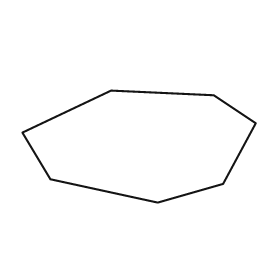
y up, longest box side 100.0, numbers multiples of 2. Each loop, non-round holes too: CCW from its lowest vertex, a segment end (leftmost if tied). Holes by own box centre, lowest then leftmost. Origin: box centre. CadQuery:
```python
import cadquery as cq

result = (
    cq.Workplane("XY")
    .moveTo(8.0, -24.0)
    .lineTo(36.0, -16.0)
    .lineTo(50.0, 10.0)
    .lineTo(32.0, 22.0)
    .lineTo(-12.0, 24.0)
    .lineTo(-50.0, 6.0)
    .lineTo(-38.0, -14.0)
    .close()
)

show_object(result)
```